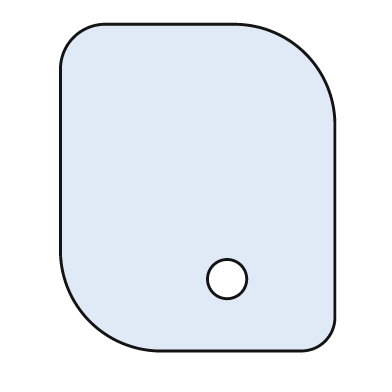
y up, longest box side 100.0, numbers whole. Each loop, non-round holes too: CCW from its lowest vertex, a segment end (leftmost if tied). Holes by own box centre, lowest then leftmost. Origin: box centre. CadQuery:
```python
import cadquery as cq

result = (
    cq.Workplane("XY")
    .moveTo(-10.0, -50.0)
    .lineTo(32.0, -50.0)
    .threePointArc((39.0, -47.0), (42.0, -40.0))
    .lineTo(42.0, 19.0)
    .threePointArc((33.0, 41.0), (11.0, 50.0))
    .lineTo(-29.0, 50.0)
    .threePointArc((-38.0, 46.0), (-42.0, 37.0))
    .lineTo(-42.0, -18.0)
    .threePointArc((-33.0, -41.0), (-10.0, -50.0))
    .close()
    .moveTo(9.0, -28.0)
    .circle(6.0)
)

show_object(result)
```